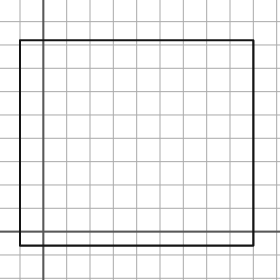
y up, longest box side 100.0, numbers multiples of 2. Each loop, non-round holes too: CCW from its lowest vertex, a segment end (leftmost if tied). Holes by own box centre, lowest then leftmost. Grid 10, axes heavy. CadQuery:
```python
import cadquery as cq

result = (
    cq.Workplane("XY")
    .moveTo(-10.0, -6.0)
    .lineTo(90.0, -6.0)
    .lineTo(90.0, 82.0)
    .lineTo(-10.0, 82.0)
    .close()
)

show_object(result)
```